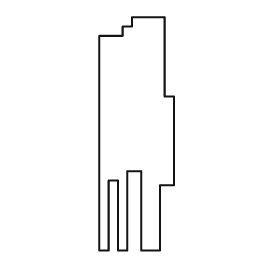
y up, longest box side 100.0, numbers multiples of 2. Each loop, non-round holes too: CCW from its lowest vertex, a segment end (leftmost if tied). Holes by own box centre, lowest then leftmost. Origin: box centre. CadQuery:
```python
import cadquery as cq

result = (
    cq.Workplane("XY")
    .moveTo(-16.0, -50.0)
    .lineTo(-12.0, -50.0)
    .lineTo(-12.0, -20.0)
    .lineTo(-8.0, -20.0)
    .lineTo(-8.0, -50.0)
    .lineTo(-4.0, -50.0)
    .lineTo(-4.0, -16.0)
    .lineTo(2.0, -16.0)
    .lineTo(2.0, -50.0)
    .lineTo(10.0, -50.0)
    .lineTo(10.0, -22.0)
    .lineTo(16.0, -22.0)
    .lineTo(16.0, 16.0)
    .lineTo(12.0, 16.0)
    .lineTo(12.0, 50.0)
    .lineTo(-2.0, 50.0)
    .lineTo(-2.0, 46.0)
    .lineTo(-6.0, 46.0)
    .lineTo(-6.0, 42.0)
    .lineTo(-16.0, 42.0)
    .close()
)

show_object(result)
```